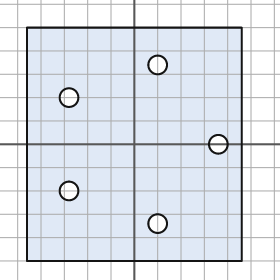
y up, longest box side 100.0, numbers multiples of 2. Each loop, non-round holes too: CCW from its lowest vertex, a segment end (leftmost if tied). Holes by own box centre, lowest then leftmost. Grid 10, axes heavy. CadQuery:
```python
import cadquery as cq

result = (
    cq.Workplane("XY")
    .moveTo(-46.0, -50.0)
    .lineTo(46.0, -50.0)
    .lineTo(46.0, 50.0)
    .lineTo(-46.0, 50.0)
    .close()
    .moveTo(10.0, -34.0)
    .circle(4.0)
    .moveTo(-28.0, -20.0)
    .circle(4.0)
    .moveTo(36.0, 0.0)
    .circle(4.0)
    .moveTo(-28.0, 20.0)
    .circle(4.0)
    .moveTo(10.0, 34.0)
    .circle(4.0)
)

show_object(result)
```